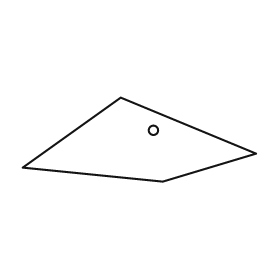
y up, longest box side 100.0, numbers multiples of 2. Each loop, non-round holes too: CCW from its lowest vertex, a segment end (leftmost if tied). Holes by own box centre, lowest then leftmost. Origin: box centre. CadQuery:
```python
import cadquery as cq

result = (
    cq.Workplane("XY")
    .moveTo(10.0, -18.0)
    .lineTo(50.0, -6.0)
    .lineTo(-8.0, 18.0)
    .lineTo(-50.0, -12.0)
    .close()
    .moveTo(6.0, 4.0)
    .circle(2.0)
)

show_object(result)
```